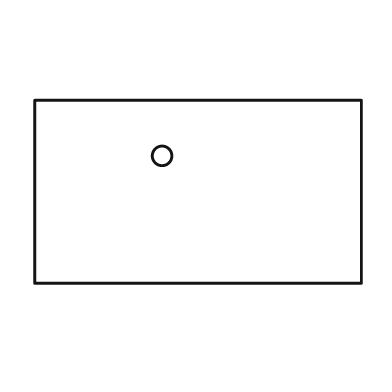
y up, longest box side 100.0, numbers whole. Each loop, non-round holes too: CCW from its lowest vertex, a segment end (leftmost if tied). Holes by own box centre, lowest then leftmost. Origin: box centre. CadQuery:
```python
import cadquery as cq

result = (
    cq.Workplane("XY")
    .moveTo(-50.0, -28.0)
    .lineTo(50.0, -28.0)
    .lineTo(50.0, 28.0)
    .lineTo(-50.0, 28.0)
    .close()
    .moveTo(-11.0, 11.0)
    .circle(3.0)
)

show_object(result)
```